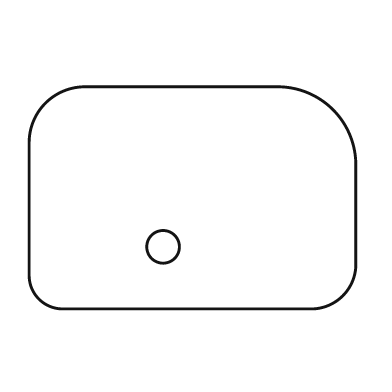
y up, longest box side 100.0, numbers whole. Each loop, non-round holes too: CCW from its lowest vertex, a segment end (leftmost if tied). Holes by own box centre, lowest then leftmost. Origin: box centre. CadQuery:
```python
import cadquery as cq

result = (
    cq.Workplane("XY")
    .moveTo(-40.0, -34.0)
    .lineTo(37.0, -34.0)
    .threePointArc((46.0, -30.0), (50.0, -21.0))
    .lineTo(50.0, 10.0)
    .threePointArc((43.0, 27.0), (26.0, 34.0))
    .lineTo(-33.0, 34.0)
    .threePointArc((-45.0, 29.0), (-50.0, 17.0))
    .lineTo(-50.0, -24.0)
    .threePointArc((-47.0, -31.0), (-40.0, -34.0))
    .close()
    .moveTo(-9.0, -15.0)
    .circle(5.0)
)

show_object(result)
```